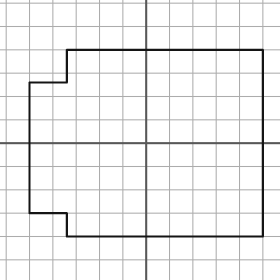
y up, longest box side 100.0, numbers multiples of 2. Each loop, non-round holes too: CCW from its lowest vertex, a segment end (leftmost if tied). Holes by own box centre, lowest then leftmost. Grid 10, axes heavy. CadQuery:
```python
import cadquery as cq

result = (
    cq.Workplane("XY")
    .moveTo(-34.0, -40.0)
    .lineTo(50.0, -40.0)
    .lineTo(50.0, 40.0)
    .lineTo(-34.0, 40.0)
    .lineTo(-34.0, 26.0)
    .lineTo(-50.0, 26.0)
    .lineTo(-50.0, -30.0)
    .lineTo(-34.0, -30.0)
    .close()
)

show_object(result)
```